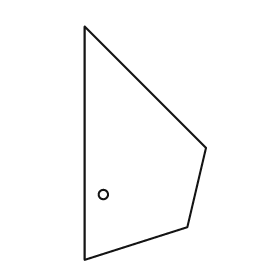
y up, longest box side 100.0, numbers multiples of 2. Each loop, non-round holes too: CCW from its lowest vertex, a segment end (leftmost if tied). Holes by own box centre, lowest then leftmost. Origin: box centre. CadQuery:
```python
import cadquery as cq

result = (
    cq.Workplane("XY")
    .moveTo(-26.0, -50.0)
    .lineTo(18.0, -36.0)
    .lineTo(26.0, -2.0)
    .lineTo(-26.0, 50.0)
    .close()
    .moveTo(-18.0, -22.0)
    .circle(2.0)
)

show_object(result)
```